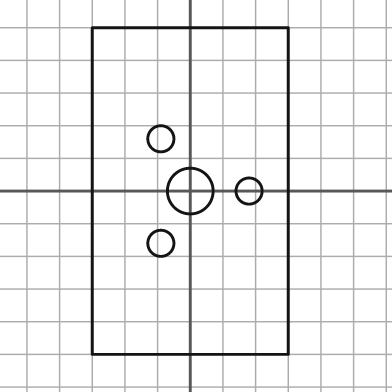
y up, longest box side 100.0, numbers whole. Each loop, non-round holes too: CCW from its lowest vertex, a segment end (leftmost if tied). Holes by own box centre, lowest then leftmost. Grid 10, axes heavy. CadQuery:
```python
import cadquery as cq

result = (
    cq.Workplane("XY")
    .moveTo(-30.0, -50.0)
    .lineTo(30.0, -50.0)
    .lineTo(30.0, 50.0)
    .lineTo(-30.0, 50.0)
    .close()
    .moveTo(-9.0, -16.0)
    .circle(4.0)
    .moveTo(0.0, 0.0)
    .circle(7.0)
    .moveTo(18.0, 0.0)
    .circle(4.0)
    .moveTo(-9.0, 16.0)
    .circle(4.0)
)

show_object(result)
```